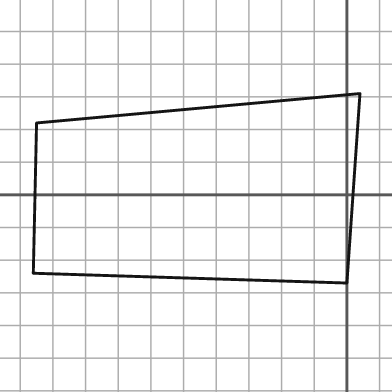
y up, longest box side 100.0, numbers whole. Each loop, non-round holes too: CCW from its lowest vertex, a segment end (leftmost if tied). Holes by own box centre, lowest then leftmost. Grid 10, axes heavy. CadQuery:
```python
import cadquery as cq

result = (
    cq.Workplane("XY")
    .moveTo(0.0, -27.0)
    .lineTo(4.0, 31.0)
    .lineTo(-95.0, 22.0)
    .lineTo(-96.0, -24.0)
    .close()
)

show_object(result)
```